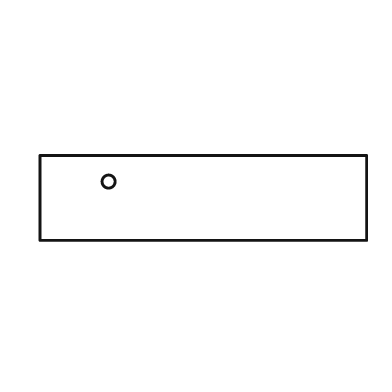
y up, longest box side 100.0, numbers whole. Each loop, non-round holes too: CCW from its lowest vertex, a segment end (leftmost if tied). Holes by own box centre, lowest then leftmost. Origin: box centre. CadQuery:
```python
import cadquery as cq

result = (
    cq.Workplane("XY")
    .moveTo(-50.0, -13.0)
    .lineTo(50.0, -13.0)
    .lineTo(50.0, 13.0)
    .lineTo(-50.0, 13.0)
    .close()
    .moveTo(-29.0, 5.0)
    .circle(2.0)
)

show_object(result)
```